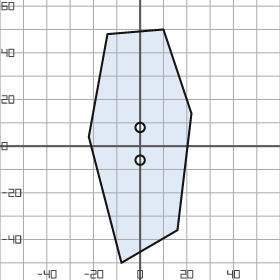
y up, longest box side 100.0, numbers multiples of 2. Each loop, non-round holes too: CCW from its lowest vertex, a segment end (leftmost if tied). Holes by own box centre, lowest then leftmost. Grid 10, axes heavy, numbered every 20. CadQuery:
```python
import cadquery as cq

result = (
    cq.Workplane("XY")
    .moveTo(-8.0, -50.0)
    .lineTo(16.0, -36.0)
    .lineTo(22.0, 14.0)
    .lineTo(10.0, 50.0)
    .lineTo(-14.0, 48.0)
    .lineTo(-22.0, 4.0)
    .close()
    .moveTo(0.0, -6.0)
    .circle(2.0)
    .moveTo(0.0, 8.0)
    .circle(2.0)
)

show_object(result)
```